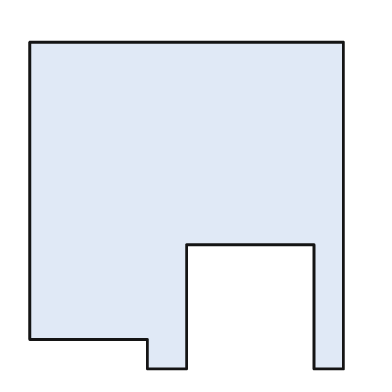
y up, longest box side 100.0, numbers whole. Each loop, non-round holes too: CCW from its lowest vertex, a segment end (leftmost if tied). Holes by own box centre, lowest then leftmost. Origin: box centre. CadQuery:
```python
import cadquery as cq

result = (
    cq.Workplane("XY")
    .moveTo(-12.0, -50.0)
    .lineTo(0.0, -50.0)
    .lineTo(0.0, -12.0)
    .lineTo(39.0, -12.0)
    .lineTo(39.0, -50.0)
    .lineTo(48.0, -50.0)
    .lineTo(48.0, 50.0)
    .lineTo(-48.0, 50.0)
    .lineTo(-48.0, -41.0)
    .lineTo(-12.0, -41.0)
    .close()
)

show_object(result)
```